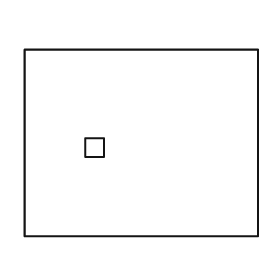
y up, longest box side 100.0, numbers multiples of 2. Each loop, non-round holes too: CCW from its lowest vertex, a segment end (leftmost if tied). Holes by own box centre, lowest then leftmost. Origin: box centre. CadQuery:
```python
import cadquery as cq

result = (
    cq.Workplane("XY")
    .moveTo(-50.0, -40.0)
    .lineTo(50.0, -40.0)
    .lineTo(50.0, 40.0)
    .lineTo(-50.0, 40.0)
    .close()
    .moveTo(-24.0, -6.0)
    .lineTo(-16.0, -6.0)
    .lineTo(-16.0, 2.0)
    .lineTo(-24.0, 2.0)
    .close()
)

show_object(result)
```